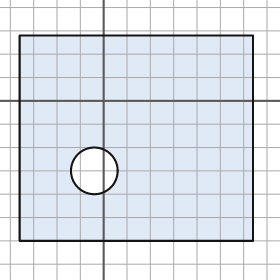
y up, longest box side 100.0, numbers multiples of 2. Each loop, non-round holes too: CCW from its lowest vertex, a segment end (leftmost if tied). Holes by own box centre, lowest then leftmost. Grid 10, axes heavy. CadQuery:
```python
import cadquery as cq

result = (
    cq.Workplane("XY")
    .moveTo(-36.0, -60.0)
    .lineTo(64.0, -60.0)
    .lineTo(64.0, 28.0)
    .lineTo(-36.0, 28.0)
    .close()
    .moveTo(-4.0, -30.0)
    .circle(10.0)
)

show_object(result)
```